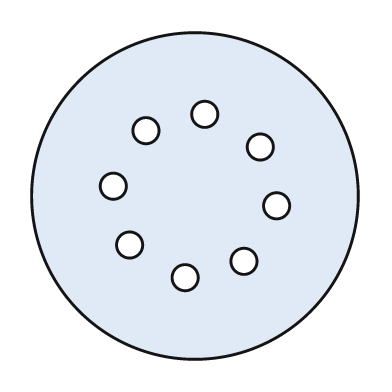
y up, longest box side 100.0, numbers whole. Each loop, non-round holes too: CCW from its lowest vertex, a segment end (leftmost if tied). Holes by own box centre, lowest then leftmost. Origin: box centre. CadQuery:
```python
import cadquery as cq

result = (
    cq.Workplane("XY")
    .moveTo(0.0, 0.0)
    .circle(50.0)
    .moveTo(-3.0, -25.0)
    .circle(4.0)
    .moveTo(15.0, -20.0)
    .circle(4.0)
    .moveTo(-20.0, -15.0)
    .circle(4.0)
    .moveTo(25.0, -3.0)
    .circle(4.0)
    .moveTo(-25.0, 3.0)
    .circle(4.0)
    .moveTo(20.0, 15.0)
    .circle(4.0)
    .moveTo(-15.0, 20.0)
    .circle(4.0)
    .moveTo(3.0, 25.0)
    .circle(4.0)
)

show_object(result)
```